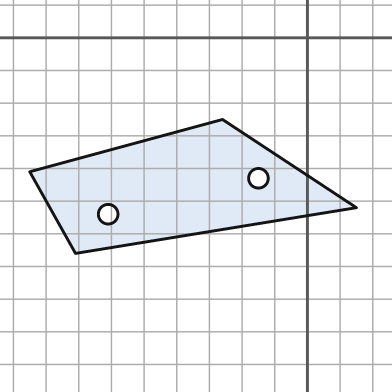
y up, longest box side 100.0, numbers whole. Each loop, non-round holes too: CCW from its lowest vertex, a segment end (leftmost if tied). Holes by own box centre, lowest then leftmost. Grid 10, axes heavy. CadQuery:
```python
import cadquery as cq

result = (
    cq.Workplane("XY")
    .moveTo(-71.0, -66.0)
    .lineTo(15.0, -52.0)
    .lineTo(-26.0, -25.0)
    .lineTo(-85.0, -41.0)
    .close()
    .moveTo(-61.0, -54.0)
    .circle(3.0)
    .moveTo(-15.0, -43.0)
    .circle(3.0)
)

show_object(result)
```